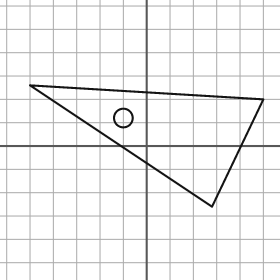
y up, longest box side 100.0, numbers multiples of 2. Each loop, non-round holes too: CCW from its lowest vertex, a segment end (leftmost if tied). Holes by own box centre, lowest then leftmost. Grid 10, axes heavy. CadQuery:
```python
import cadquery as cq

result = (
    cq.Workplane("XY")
    .moveTo(28.0, -26.0)
    .lineTo(50.0, 20.0)
    .lineTo(-50.0, 26.0)
    .close()
    .moveTo(-10.0, 12.0)
    .circle(4.0)
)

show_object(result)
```